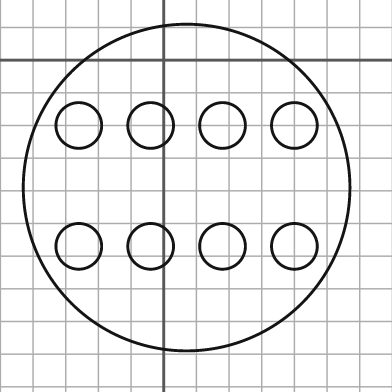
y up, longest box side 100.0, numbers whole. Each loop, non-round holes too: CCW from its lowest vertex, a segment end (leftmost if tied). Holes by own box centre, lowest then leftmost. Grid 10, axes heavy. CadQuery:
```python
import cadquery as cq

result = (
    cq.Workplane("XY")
    .moveTo(7.0, -39.0)
    .circle(50.0)
    .moveTo(-26.0, -57.0)
    .circle(7.0)
    .moveTo(-4.0, -57.0)
    .circle(7.0)
    .moveTo(18.0, -57.0)
    .circle(7.0)
    .moveTo(40.0, -57.0)
    .circle(7.0)
    .moveTo(-26.0, -20.0)
    .circle(7.0)
    .moveTo(-4.0, -20.0)
    .circle(7.0)
    .moveTo(18.0, -20.0)
    .circle(7.0)
    .moveTo(40.0, -20.0)
    .circle(7.0)
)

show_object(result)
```